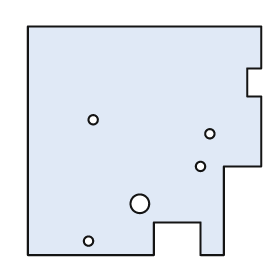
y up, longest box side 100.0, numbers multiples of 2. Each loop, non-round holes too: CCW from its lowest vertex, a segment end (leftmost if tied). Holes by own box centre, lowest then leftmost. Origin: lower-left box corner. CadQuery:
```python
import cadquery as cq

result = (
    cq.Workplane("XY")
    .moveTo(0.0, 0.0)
    .lineTo(54.0, 0.0)
    .lineTo(54.0, 14.0)
    .lineTo(74.0, 14.0)
    .lineTo(74.0, 0.0)
    .lineTo(84.0, 0.0)
    .lineTo(84.0, 38.0)
    .lineTo(100.0, 38.0)
    .lineTo(100.0, 68.0)
    .lineTo(94.0, 68.0)
    .lineTo(94.0, 80.0)
    .lineTo(100.0, 80.0)
    .lineTo(100.0, 98.0)
    .lineTo(0.0, 98.0)
    .close()
    .moveTo(26.0, 6.0)
    .circle(2.0)
    .moveTo(48.0, 22.0)
    .circle(4.0)
    .moveTo(74.0, 38.0)
    .circle(2.0)
    .moveTo(78.0, 52.0)
    .circle(2.0)
    .moveTo(28.0, 58.0)
    .circle(2.0)
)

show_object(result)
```